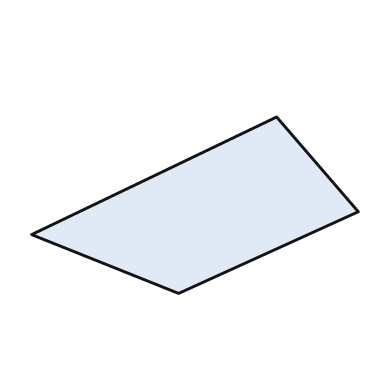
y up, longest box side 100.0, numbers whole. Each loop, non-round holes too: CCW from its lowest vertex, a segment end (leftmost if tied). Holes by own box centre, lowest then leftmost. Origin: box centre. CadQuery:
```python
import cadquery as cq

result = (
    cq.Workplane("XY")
    .moveTo(-5.0, -27.0)
    .lineTo(50.0, -2.0)
    .lineTo(25.0, 27.0)
    .lineTo(-50.0, -9.0)
    .close()
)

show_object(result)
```